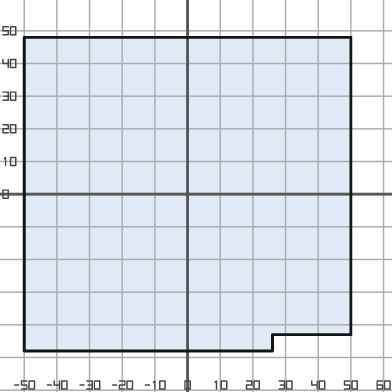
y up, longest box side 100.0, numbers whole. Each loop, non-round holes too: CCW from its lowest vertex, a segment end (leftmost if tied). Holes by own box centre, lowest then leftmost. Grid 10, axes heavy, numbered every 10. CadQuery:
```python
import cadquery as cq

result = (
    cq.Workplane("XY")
    .moveTo(-50.0, -48.0)
    .lineTo(26.0, -48.0)
    .lineTo(26.0, -43.0)
    .lineTo(50.0, -43.0)
    .lineTo(50.0, 48.0)
    .lineTo(-50.0, 48.0)
    .close()
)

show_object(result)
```